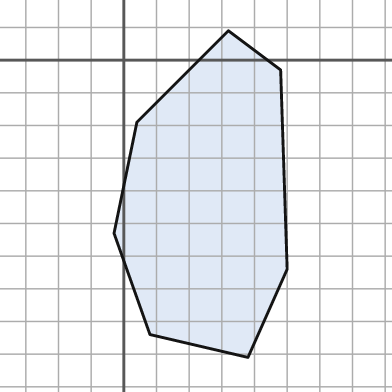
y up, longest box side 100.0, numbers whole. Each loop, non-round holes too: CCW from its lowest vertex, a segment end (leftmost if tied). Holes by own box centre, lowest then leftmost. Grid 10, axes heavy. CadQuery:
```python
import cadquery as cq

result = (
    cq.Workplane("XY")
    .moveTo(38.0, -91.0)
    .lineTo(50.0, -64.0)
    .lineTo(48.0, -3.0)
    .lineTo(32.0, 9.0)
    .lineTo(4.0, -19.0)
    .lineTo(-3.0, -53.0)
    .lineTo(8.0, -84.0)
    .close()
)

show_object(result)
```